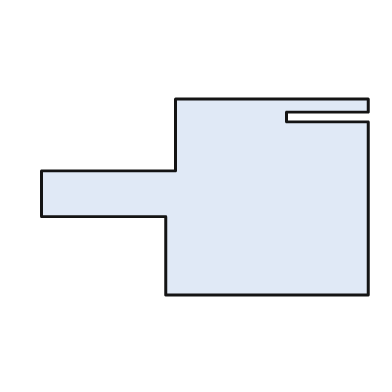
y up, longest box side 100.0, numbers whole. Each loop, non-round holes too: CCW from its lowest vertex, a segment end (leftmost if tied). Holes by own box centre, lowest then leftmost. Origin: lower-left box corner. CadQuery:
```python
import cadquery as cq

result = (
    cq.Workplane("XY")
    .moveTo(38.0, 0.0)
    .lineTo(100.0, 0.0)
    .lineTo(100.0, 53.0)
    .lineTo(75.0, 53.0)
    .lineTo(75.0, 56.0)
    .lineTo(100.0, 56.0)
    .lineTo(100.0, 60.0)
    .lineTo(41.0, 60.0)
    .lineTo(41.0, 38.0)
    .lineTo(0.0, 38.0)
    .lineTo(0.0, 24.0)
    .lineTo(38.0, 24.0)
    .close()
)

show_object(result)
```